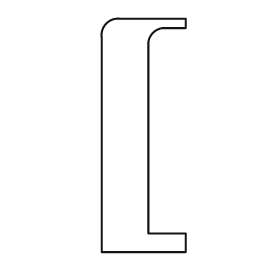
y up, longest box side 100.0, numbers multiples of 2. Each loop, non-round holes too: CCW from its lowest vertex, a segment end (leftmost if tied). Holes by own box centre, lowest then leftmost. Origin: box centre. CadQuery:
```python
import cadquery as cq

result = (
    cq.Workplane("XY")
    .moveTo(-18.0, -50.0)
    .lineTo(18.0, -50.0)
    .lineTo(18.0, -42.0)
    .lineTo(2.0, -42.0)
    .lineTo(2.0, 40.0)
    .threePointArc((4.0, 44.0), (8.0, 46.0))
    .lineTo(18.0, 46.0)
    .lineTo(18.0, 50.0)
    .lineTo(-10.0, 50.0)
    .threePointArc((-16.0, 48.0), (-18.0, 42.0))
    .close()
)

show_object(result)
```